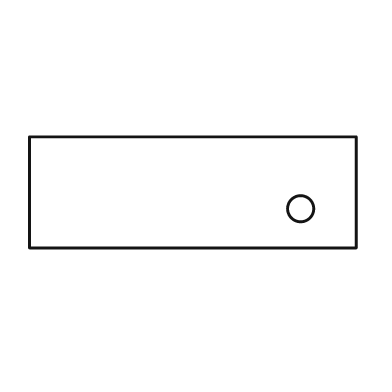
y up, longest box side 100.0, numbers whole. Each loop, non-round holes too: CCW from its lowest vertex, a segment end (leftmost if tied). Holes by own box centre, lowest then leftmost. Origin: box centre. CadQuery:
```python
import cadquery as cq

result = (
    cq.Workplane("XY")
    .moveTo(-50.0, -17.0)
    .lineTo(50.0, -17.0)
    .lineTo(50.0, 17.0)
    .lineTo(-50.0, 17.0)
    .close()
    .moveTo(33.0, -5.0)
    .circle(4.0)
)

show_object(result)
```